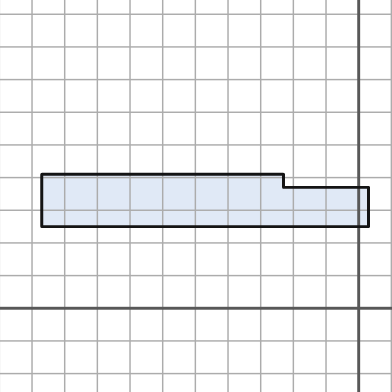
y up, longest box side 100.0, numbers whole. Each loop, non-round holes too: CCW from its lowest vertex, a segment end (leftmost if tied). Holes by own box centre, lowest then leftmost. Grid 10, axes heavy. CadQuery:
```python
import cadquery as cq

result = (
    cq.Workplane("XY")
    .moveTo(-97.0, 25.0)
    .lineTo(3.0, 25.0)
    .lineTo(3.0, 37.0)
    .lineTo(-23.0, 37.0)
    .lineTo(-23.0, 41.0)
    .lineTo(-97.0, 41.0)
    .close()
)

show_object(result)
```